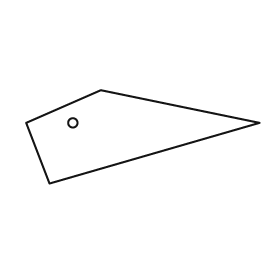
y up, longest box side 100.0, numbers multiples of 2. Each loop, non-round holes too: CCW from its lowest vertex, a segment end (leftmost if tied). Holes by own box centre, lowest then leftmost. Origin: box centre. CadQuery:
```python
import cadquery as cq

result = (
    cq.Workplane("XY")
    .moveTo(-40.0, -20.0)
    .lineTo(50.0, 6.0)
    .lineTo(-18.0, 20.0)
    .lineTo(-50.0, 6.0)
    .close()
    .moveTo(-30.0, 6.0)
    .circle(2.0)
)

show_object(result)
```